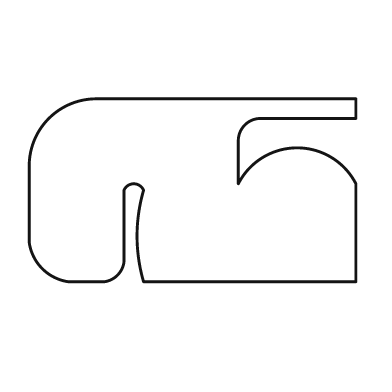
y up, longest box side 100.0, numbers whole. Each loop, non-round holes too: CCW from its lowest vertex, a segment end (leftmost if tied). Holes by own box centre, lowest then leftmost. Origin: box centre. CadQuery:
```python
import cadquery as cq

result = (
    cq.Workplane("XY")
    .moveTo(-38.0, -28.0)
    .lineTo(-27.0, -28.0)
    .threePointArc((-23.0, -26.0), (-21.0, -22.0))
    .lineTo(-21.0, 0.0)
    .threePointArc((-18.0, 2.0), (-15.0, 0.0))
    .threePointArc((-17.0, -14.0), (-15.0, -28.0))
    .lineTo(50.0, -28.0)
    .lineTo(50.0, 2.0)
    .threePointArc((32.0, 13.0), (14.0, 2.0))
    .lineTo(14.0, 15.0)
    .threePointArc((16.0, 20.0), (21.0, 22.0))
    .lineTo(50.0, 22.0)
    .lineTo(50.0, 28.0)
    .lineTo(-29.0, 28.0)
    .threePointArc((-44.0, 22.0), (-50.0, 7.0))
    .lineTo(-50.0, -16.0)
    .threePointArc((-46.0, -24.0), (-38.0, -28.0))
    .close()
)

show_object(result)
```